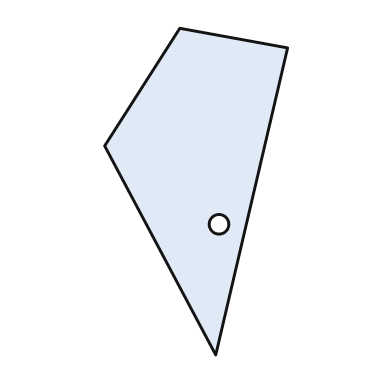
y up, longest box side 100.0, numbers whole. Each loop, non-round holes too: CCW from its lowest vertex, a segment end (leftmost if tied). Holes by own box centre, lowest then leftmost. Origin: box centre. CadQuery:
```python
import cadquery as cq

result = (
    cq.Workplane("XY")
    .moveTo(6.0, -50.0)
    .lineTo(28.0, 44.0)
    .lineTo(-5.0, 50.0)
    .lineTo(-28.0, 14.0)
    .close()
    .moveTo(7.0, -10.0)
    .circle(3.0)
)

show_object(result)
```